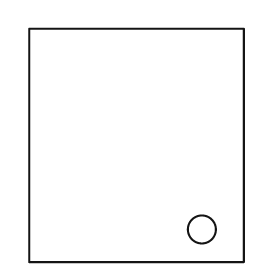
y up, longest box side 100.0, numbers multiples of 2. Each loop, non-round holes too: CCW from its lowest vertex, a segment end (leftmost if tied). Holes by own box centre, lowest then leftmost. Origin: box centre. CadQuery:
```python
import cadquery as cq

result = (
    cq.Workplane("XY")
    .moveTo(-46.0, -50.0)
    .lineTo(46.0, -50.0)
    .lineTo(46.0, 50.0)
    .lineTo(-46.0, 50.0)
    .close()
    .moveTo(28.0, -36.0)
    .circle(6.0)
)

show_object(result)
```